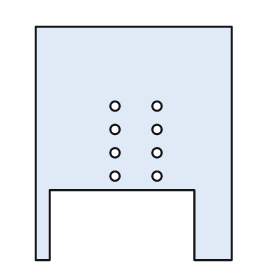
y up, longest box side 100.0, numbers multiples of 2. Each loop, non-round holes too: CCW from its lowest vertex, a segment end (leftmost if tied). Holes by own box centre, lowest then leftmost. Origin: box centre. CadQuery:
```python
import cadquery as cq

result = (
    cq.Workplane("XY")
    .moveTo(-42.0, -50.0)
    .lineTo(-36.0, -50.0)
    .lineTo(-36.0, -20.0)
    .lineTo(26.0, -20.0)
    .lineTo(26.0, -50.0)
    .lineTo(42.0, -50.0)
    .lineTo(42.0, 50.0)
    .lineTo(-42.0, 50.0)
    .close()
    .moveTo(-8.0, -14.0)
    .circle(2.0)
    .moveTo(10.0, -14.0)
    .circle(2.0)
    .moveTo(-8.0, -4.0)
    .circle(2.0)
    .moveTo(10.0, -4.0)
    .circle(2.0)
    .moveTo(-8.0, 6.0)
    .circle(2.0)
    .moveTo(10.0, 6.0)
    .circle(2.0)
    .moveTo(-8.0, 16.0)
    .circle(2.0)
    .moveTo(10.0, 16.0)
    .circle(2.0)
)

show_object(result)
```